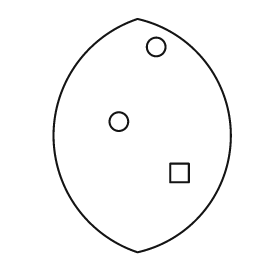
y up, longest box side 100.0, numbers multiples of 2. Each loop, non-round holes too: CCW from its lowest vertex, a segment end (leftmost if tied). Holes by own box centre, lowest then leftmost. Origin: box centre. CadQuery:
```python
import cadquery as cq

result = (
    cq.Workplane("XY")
    .moveTo(-2.0, -50.0)
    .threePointArc((38.0, 0.0), (-2.0, 50.0))
    .threePointArc((-38.0, 0.0), (-2.0, -50.0))
    .close()
    .moveTo(12.0, -20.0)
    .lineTo(20.0, -20.0)
    .lineTo(20.0, -12.0)
    .lineTo(12.0, -12.0)
    .close()
    .moveTo(-10.0, 6.0)
    .circle(4.0)
    .moveTo(6.0, 38.0)
    .circle(4.0)
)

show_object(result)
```